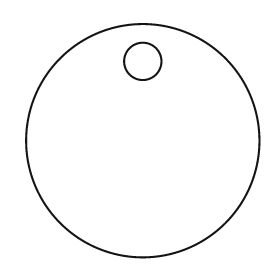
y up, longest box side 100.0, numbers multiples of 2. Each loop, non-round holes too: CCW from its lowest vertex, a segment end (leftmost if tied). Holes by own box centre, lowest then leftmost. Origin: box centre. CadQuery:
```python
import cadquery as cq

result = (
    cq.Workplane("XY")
    .moveTo(0.0, 0.0)
    .circle(50.0)
    .moveTo(0.0, 34.0)
    .circle(8.0)
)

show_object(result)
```